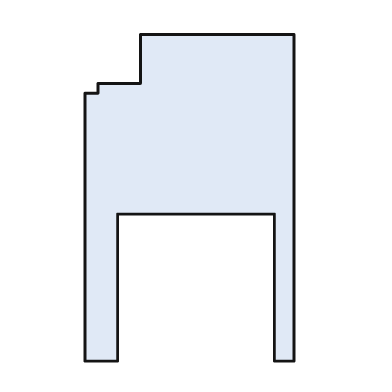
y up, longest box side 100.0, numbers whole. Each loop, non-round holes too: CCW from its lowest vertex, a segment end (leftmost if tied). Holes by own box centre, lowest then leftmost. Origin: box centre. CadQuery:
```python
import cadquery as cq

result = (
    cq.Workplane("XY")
    .moveTo(-32.0, -50.0)
    .lineTo(-22.0, -50.0)
    .lineTo(-22.0, -5.0)
    .lineTo(26.0, -5.0)
    .lineTo(26.0, -50.0)
    .lineTo(32.0, -50.0)
    .lineTo(32.0, 50.0)
    .lineTo(-15.0, 50.0)
    .lineTo(-15.0, 35.0)
    .lineTo(-28.0, 35.0)
    .lineTo(-28.0, 32.0)
    .lineTo(-32.0, 32.0)
    .close()
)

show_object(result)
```